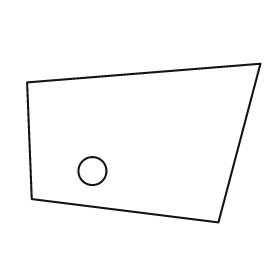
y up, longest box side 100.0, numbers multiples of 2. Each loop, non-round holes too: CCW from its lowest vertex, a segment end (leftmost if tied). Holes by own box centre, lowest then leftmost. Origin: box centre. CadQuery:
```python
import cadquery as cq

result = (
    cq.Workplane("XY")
    .moveTo(32.0, -34.0)
    .lineTo(50.0, 34.0)
    .lineTo(-50.0, 26.0)
    .lineTo(-48.0, -24.0)
    .close()
    .moveTo(-22.0, -12.0)
    .circle(6.0)
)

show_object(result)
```